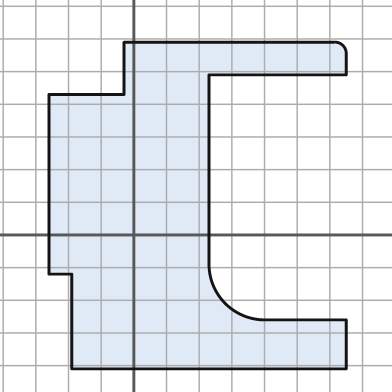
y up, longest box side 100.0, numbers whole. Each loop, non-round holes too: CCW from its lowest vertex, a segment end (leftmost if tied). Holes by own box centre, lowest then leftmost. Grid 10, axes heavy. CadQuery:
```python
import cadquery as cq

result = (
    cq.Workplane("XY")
    .moveTo(-19.0, -41.0)
    .lineTo(65.0, -41.0)
    .lineTo(65.0, -26.0)
    .lineTo(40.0, -26.0)
    .threePointArc((28.0, -21.0), (23.0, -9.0))
    .lineTo(23.0, 49.0)
    .lineTo(65.0, 49.0)
    .lineTo(65.0, 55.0)
    .threePointArc((64.0, 58.0), (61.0, 59.0))
    .lineTo(-3.0, 59.0)
    .lineTo(-3.0, 43.0)
    .lineTo(-26.0, 43.0)
    .lineTo(-26.0, -12.0)
    .lineTo(-19.0, -12.0)
    .close()
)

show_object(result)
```